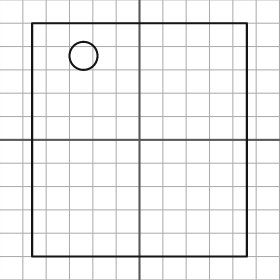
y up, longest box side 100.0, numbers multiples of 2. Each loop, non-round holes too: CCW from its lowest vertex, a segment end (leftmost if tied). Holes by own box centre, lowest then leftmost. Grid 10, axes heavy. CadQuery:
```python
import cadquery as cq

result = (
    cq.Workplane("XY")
    .moveTo(-46.0, -50.0)
    .lineTo(46.0, -50.0)
    .lineTo(46.0, 50.0)
    .lineTo(-46.0, 50.0)
    .close()
    .moveTo(-24.0, 36.0)
    .circle(6.0)
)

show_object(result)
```